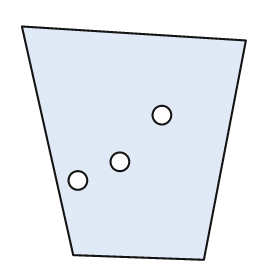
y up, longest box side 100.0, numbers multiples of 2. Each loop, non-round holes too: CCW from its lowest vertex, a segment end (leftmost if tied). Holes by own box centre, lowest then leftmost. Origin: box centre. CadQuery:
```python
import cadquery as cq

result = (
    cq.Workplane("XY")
    .moveTo(30.0, -50.0)
    .lineTo(48.0, 44.0)
    .lineTo(-48.0, 50.0)
    .lineTo(-26.0, -48.0)
    .close()
    .moveTo(-24.0, -16.0)
    .circle(4.0)
    .moveTo(-6.0, -8.0)
    .circle(4.0)
    .moveTo(12.0, 12.0)
    .circle(4.0)
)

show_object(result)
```